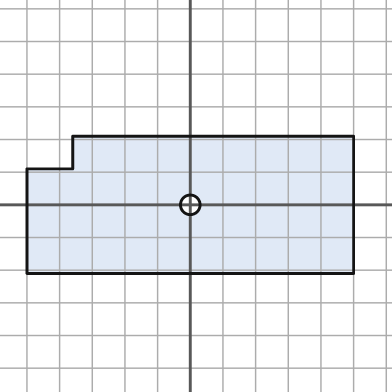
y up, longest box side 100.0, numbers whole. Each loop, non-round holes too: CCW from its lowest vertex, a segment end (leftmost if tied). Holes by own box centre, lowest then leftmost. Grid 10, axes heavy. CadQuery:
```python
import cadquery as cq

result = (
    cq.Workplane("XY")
    .moveTo(-50.0, -21.0)
    .lineTo(50.0, -21.0)
    .lineTo(50.0, 21.0)
    .lineTo(-36.0, 21.0)
    .lineTo(-36.0, 11.0)
    .lineTo(-50.0, 11.0)
    .close()
    .moveTo(0.0, 0.0)
    .circle(3.0)
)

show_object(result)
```